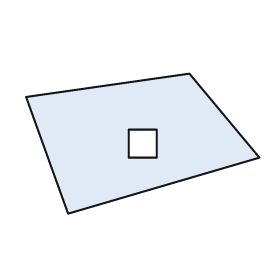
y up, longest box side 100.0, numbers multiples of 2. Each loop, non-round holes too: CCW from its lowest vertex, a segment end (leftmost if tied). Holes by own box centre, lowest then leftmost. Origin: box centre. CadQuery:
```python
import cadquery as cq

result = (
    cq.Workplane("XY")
    .moveTo(-32.0, -30.0)
    .lineTo(50.0, -6.0)
    .lineTo(20.0, 30.0)
    .lineTo(-50.0, 20.0)
    .close()
    .moveTo(-6.0, -6.0)
    .lineTo(6.0, -6.0)
    .lineTo(6.0, 6.0)
    .lineTo(-6.0, 6.0)
    .close()
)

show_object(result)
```